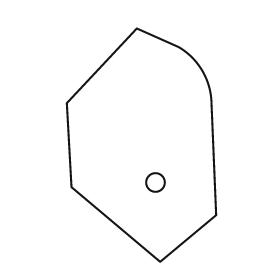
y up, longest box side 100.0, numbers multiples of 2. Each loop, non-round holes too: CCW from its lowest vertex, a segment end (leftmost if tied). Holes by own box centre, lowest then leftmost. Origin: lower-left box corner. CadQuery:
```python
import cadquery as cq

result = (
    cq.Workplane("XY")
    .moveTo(40.0, 0.0)
    .lineTo(64.0, 20.0)
    .lineTo(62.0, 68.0)
    .threePointArc((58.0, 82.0), (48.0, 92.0))
    .lineTo(30.0, 100.0)
    .lineTo(0.0, 68.0)
    .lineTo(2.0, 32.0)
    .close()
    .moveTo(38.0, 34.0)
    .circle(4.0)
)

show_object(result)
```